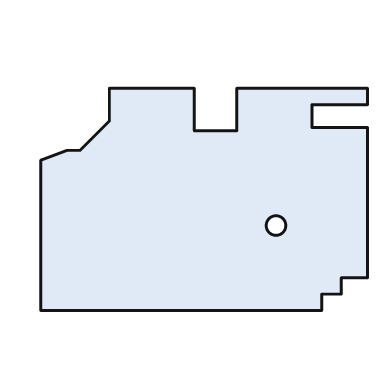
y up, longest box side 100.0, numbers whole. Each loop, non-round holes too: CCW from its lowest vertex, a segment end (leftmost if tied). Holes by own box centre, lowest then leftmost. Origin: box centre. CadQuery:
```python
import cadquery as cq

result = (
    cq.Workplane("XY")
    .moveTo(-50.0, -34.0)
    .lineTo(36.0, -34.0)
    .lineTo(36.0, -29.0)
    .lineTo(42.0, -29.0)
    .lineTo(42.0, -24.0)
    .lineTo(50.0, -24.0)
    .lineTo(50.0, 22.0)
    .lineTo(33.0, 22.0)
    .lineTo(33.0, 29.0)
    .lineTo(50.0, 29.0)
    .lineTo(50.0, 34.0)
    .lineTo(10.0, 34.0)
    .lineTo(10.0, 21.0)
    .lineTo(-3.0, 21.0)
    .lineTo(-3.0, 34.0)
    .lineTo(-29.0, 34.0)
    .lineTo(-29.0, 24.0)
    .lineTo(-38.0, 15.0)
    .lineTo(-42.0, 15.0)
    .lineTo(-50.0, 12.0)
    .close()
    .moveTo(22.0, -8.0)
    .circle(3.0)
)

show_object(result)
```